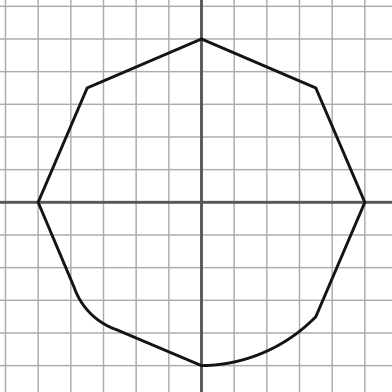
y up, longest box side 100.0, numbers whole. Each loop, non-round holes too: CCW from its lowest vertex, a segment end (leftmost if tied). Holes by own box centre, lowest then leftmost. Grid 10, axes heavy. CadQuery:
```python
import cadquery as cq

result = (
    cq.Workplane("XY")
    .moveTo(0.0, -50.0)
    .threePointArc((19.0, -46.0), (35.0, -35.0))
    .lineTo(50.0, 0.0)
    .lineTo(35.0, 35.0)
    .lineTo(0.0, 50.0)
    .lineTo(-35.0, 35.0)
    .lineTo(-50.0, 0.0)
    .lineTo(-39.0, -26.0)
    .threePointArc((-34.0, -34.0), (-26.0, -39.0))
    .close()
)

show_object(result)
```